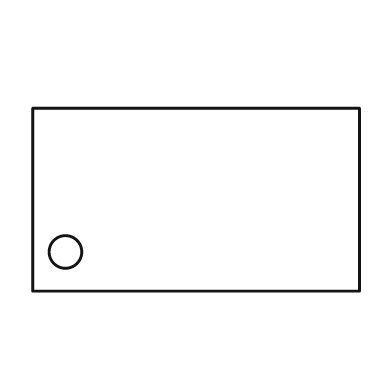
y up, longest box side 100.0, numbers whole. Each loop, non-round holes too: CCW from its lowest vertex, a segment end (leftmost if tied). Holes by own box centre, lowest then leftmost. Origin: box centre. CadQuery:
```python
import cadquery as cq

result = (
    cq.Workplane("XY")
    .moveTo(-50.0, -28.0)
    .lineTo(50.0, -28.0)
    .lineTo(50.0, 28.0)
    .lineTo(-50.0, 28.0)
    .close()
    .moveTo(-40.0, -16.0)
    .circle(5.0)
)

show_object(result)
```